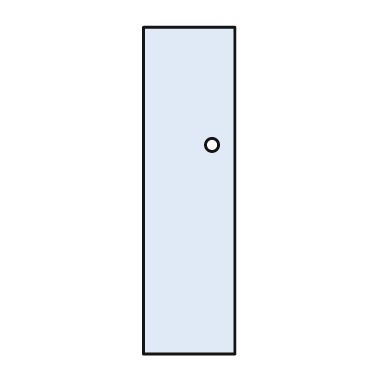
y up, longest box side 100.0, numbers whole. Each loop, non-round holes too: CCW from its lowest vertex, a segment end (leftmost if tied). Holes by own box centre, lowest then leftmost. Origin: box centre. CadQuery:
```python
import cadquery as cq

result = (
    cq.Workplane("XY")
    .moveTo(-14.0, -50.0)
    .lineTo(14.0, -50.0)
    .lineTo(14.0, 50.0)
    .lineTo(-14.0, 50.0)
    .close()
    .moveTo(7.0, 14.0)
    .circle(2.0)
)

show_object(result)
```